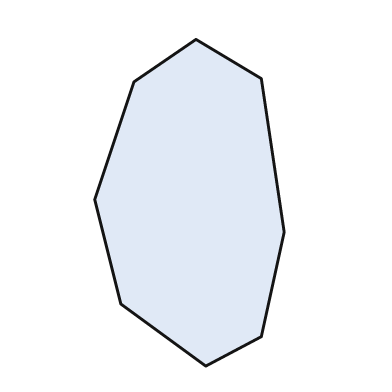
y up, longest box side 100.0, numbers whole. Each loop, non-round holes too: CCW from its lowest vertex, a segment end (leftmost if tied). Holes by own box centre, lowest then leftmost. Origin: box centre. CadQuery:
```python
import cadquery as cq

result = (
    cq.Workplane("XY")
    .moveTo(5.0, -50.0)
    .lineTo(22.0, -41.0)
    .lineTo(29.0, -9.0)
    .lineTo(22.0, 38.0)
    .lineTo(2.0, 50.0)
    .lineTo(-17.0, 37.0)
    .lineTo(-29.0, 1.0)
    .lineTo(-21.0, -31.0)
    .close()
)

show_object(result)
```